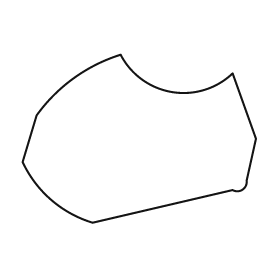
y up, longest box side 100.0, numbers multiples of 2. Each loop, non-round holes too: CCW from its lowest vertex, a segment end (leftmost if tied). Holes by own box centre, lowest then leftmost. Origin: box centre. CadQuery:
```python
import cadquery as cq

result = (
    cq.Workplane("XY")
    .moveTo(-20.0, -36.0)
    .lineTo(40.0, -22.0)
    .threePointArc((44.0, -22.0), (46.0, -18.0))
    .lineTo(50.0, 0.0)
    .lineTo(40.0, 28.0)
    .threePointArc((14.0, 20.0), (-8.0, 36.0))
    .threePointArc((-28.0, 26.0), (-44.0, 10.0))
    .lineTo(-50.0, -10.0)
    .threePointArc((-38.0, -26.0), (-20.0, -36.0))
    .close()
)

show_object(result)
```